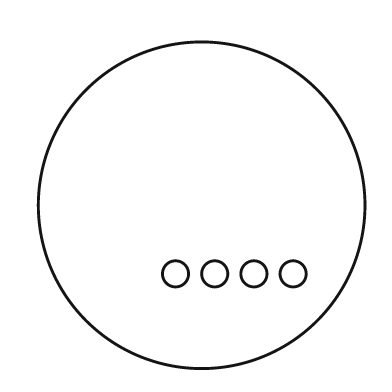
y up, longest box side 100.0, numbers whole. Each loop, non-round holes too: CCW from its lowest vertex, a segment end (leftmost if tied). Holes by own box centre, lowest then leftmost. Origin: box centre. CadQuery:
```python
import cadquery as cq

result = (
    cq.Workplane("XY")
    .moveTo(0.0, 0.0)
    .circle(50.0)
    .moveTo(-8.0, -21.0)
    .circle(4.0)
    .moveTo(4.0, -21.0)
    .circle(4.0)
    .moveTo(16.0, -21.0)
    .circle(4.0)
    .moveTo(28.0, -21.0)
    .circle(4.0)
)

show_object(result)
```